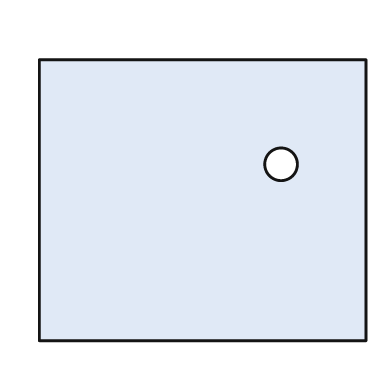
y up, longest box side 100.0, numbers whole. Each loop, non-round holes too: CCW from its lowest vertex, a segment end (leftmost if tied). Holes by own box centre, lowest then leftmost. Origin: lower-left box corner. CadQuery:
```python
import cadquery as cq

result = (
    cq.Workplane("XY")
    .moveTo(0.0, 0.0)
    .lineTo(100.0, 0.0)
    .lineTo(100.0, 86.0)
    .lineTo(0.0, 86.0)
    .close()
    .moveTo(74.0, 54.0)
    .circle(5.0)
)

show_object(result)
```